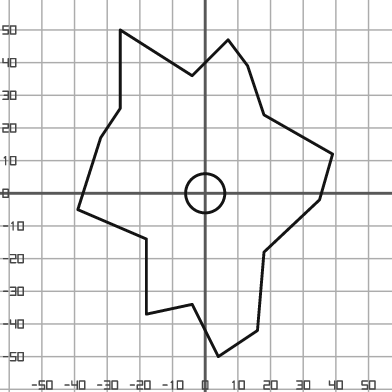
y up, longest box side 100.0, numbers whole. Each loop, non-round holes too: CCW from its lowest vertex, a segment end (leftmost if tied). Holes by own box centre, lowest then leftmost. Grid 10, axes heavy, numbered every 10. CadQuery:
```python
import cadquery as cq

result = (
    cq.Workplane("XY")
    .moveTo(4.0, -50.0)
    .lineTo(16.0, -42.0)
    .lineTo(18.0, -18.0)
    .lineTo(35.0, -2.0)
    .lineTo(39.0, 12.0)
    .lineTo(18.0, 24.0)
    .lineTo(13.0, 39.0)
    .lineTo(7.0, 47.0)
    .lineTo(-4.0, 36.0)
    .lineTo(-26.0, 50.0)
    .lineTo(-26.0, 26.0)
    .lineTo(-32.0, 17.0)
    .lineTo(-39.0, -5.0)
    .lineTo(-18.0, -14.0)
    .lineTo(-18.0, -37.0)
    .lineTo(-4.0, -34.0)
    .close()
    .moveTo(0.0, 0.0)
    .circle(6.0)
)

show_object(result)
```